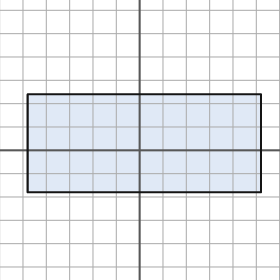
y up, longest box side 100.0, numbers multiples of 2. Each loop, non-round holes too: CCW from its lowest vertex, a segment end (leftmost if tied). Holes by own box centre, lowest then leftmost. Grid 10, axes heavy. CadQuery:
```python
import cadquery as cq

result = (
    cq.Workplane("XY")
    .moveTo(-48.0, -18.0)
    .lineTo(52.0, -18.0)
    .lineTo(52.0, 24.0)
    .lineTo(-48.0, 24.0)
    .close()
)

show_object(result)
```